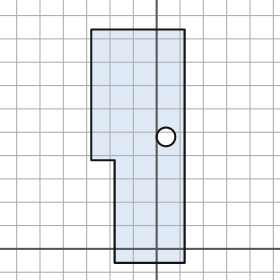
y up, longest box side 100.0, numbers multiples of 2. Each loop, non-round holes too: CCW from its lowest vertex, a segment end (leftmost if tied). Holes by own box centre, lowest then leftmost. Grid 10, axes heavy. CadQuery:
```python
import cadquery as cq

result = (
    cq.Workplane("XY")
    .moveTo(-18.0, -6.0)
    .lineTo(12.0, -6.0)
    .lineTo(12.0, 94.0)
    .lineTo(-28.0, 94.0)
    .lineTo(-28.0, 38.0)
    .lineTo(-18.0, 38.0)
    .close()
    .moveTo(4.0, 48.0)
    .circle(4.0)
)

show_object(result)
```